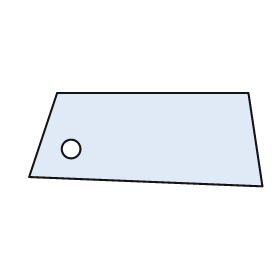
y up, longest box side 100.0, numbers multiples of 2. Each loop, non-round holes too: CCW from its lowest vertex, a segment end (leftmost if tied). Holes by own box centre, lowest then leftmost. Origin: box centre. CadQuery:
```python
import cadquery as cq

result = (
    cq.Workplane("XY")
    .moveTo(50.0, -20.0)
    .lineTo(44.0, 20.0)
    .lineTo(-38.0, 20.0)
    .lineTo(-50.0, -16.0)
    .close()
    .moveTo(-32.0, -4.0)
    .circle(4.0)
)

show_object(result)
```